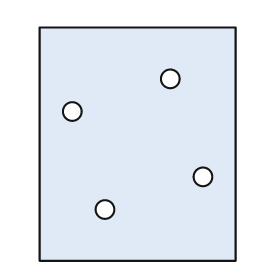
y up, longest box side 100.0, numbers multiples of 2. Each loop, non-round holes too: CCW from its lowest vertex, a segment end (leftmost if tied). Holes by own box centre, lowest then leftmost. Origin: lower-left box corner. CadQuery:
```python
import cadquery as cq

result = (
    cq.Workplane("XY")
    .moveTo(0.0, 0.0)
    .lineTo(84.0, 0.0)
    .lineTo(84.0, 100.0)
    .lineTo(0.0, 100.0)
    .close()
    .moveTo(28.0, 22.0)
    .circle(4.0)
    .moveTo(70.0, 36.0)
    .circle(4.0)
    .moveTo(14.0, 64.0)
    .circle(4.0)
    .moveTo(56.0, 78.0)
    .circle(4.0)
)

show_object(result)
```